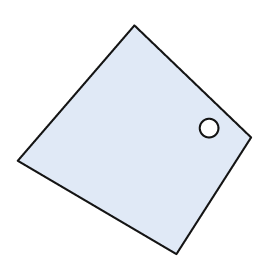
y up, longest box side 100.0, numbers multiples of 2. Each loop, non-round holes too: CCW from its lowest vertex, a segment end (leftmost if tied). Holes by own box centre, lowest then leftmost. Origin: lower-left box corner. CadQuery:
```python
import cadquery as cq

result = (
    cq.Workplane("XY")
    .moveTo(68.0, 0.0)
    .lineTo(100.0, 50.0)
    .lineTo(50.0, 98.0)
    .lineTo(0.0, 40.0)
    .close()
    .moveTo(82.0, 54.0)
    .circle(4.0)
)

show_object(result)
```